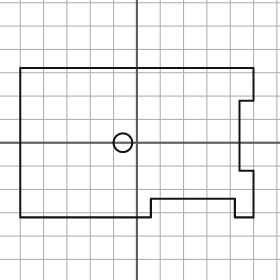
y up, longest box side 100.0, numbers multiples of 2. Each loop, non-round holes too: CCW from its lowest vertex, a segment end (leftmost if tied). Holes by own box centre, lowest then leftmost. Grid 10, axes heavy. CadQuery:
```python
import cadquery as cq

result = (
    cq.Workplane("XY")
    .moveTo(-50.0, -32.0)
    .lineTo(6.0, -32.0)
    .lineTo(6.0, -24.0)
    .lineTo(42.0, -24.0)
    .lineTo(42.0, -32.0)
    .lineTo(50.0, -32.0)
    .lineTo(50.0, -12.0)
    .lineTo(44.0, -12.0)
    .lineTo(44.0, 18.0)
    .lineTo(50.0, 18.0)
    .lineTo(50.0, 32.0)
    .lineTo(-50.0, 32.0)
    .close()
    .moveTo(-6.0, 0.0)
    .circle(4.0)
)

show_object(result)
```